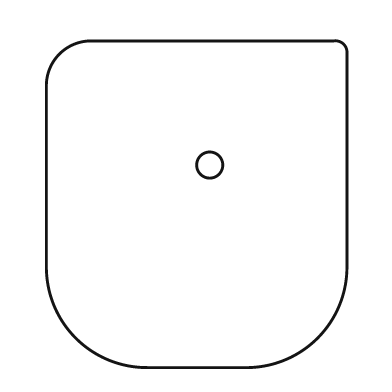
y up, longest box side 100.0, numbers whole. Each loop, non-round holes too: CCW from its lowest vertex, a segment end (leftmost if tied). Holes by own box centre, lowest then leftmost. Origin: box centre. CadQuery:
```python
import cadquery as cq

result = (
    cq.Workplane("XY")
    .moveTo(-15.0, -50.0)
    .lineTo(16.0, -50.0)
    .threePointArc((37.0, -41.0), (46.0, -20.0))
    .lineTo(46.0, 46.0)
    .threePointArc((45.0, 49.0), (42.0, 50.0))
    .lineTo(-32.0, 50.0)
    .threePointArc((-42.0, 46.0), (-46.0, 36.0))
    .lineTo(-46.0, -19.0)
    .threePointArc((-37.0, -41.0), (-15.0, -50.0))
    .close()
    .moveTo(4.0, 12.0)
    .circle(4.0)
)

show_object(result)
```